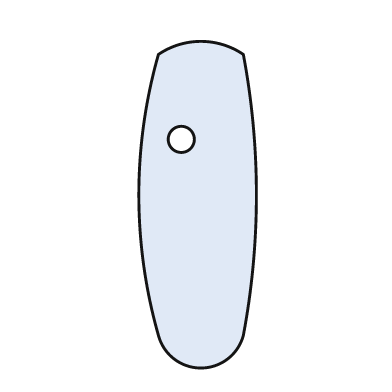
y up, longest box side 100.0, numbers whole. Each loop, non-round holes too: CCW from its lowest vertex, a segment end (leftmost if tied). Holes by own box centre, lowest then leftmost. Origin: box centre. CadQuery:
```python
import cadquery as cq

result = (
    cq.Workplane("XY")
    .moveTo(-12.0, -40.0)
    .threePointArc((1.0, -50.0), (14.0, -40.0))
    .threePointArc((18.0, 3.0), (14.0, 46.0))
    .threePointArc((1.0, 50.0), (-12.0, 46.0))
    .threePointArc((-18.0, 3.0), (-12.0, -40.0))
    .close()
    .moveTo(-5.0, 20.0)
    .circle(4.0)
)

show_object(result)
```